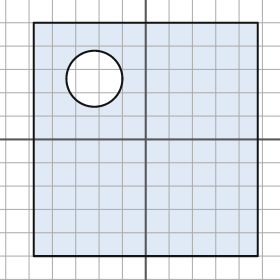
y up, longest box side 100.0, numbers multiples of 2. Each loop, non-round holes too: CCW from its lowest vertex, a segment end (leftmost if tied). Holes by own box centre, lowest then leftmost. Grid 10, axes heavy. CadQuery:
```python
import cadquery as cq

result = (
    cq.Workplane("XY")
    .moveTo(-48.0, -50.0)
    .lineTo(48.0, -50.0)
    .lineTo(48.0, 50.0)
    .lineTo(-48.0, 50.0)
    .close()
    .moveTo(-22.0, 26.0)
    .circle(12.0)
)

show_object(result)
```